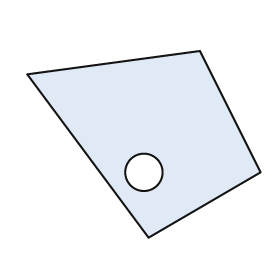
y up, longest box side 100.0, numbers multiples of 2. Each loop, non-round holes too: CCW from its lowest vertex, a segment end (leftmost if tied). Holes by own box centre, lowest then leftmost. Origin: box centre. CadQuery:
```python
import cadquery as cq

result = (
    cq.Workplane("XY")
    .moveTo(2.0, -40.0)
    .lineTo(50.0, -12.0)
    .lineTo(24.0, 40.0)
    .lineTo(-50.0, 30.0)
    .close()
    .moveTo(0.0, -12.0)
    .circle(8.0)
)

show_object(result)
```